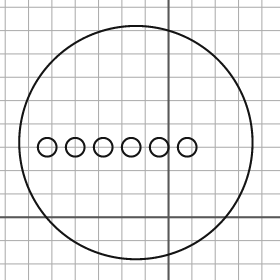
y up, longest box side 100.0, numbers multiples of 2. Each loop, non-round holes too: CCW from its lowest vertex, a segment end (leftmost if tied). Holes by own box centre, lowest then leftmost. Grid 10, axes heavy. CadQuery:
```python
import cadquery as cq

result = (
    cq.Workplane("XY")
    .moveTo(-14.0, 32.0)
    .circle(50.0)
    .moveTo(-52.0, 30.0)
    .circle(4.0)
    .moveTo(-40.0, 30.0)
    .circle(4.0)
    .moveTo(-28.0, 30.0)
    .circle(4.0)
    .moveTo(-16.0, 30.0)
    .circle(4.0)
    .moveTo(-4.0, 30.0)
    .circle(4.0)
    .moveTo(8.0, 30.0)
    .circle(4.0)
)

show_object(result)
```